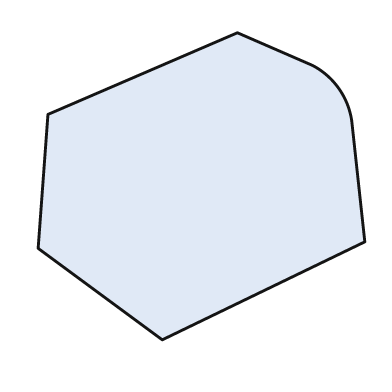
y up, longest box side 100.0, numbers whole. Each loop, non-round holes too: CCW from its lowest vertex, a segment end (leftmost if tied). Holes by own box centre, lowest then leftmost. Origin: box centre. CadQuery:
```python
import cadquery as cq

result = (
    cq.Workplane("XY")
    .moveTo(-12.0, -47.0)
    .lineTo(50.0, -17.0)
    .lineTo(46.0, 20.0)
    .threePointArc((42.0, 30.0), (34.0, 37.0))
    .lineTo(11.0, 47.0)
    .lineTo(-47.0, 22.0)
    .lineTo(-50.0, -19.0)
    .close()
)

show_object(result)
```